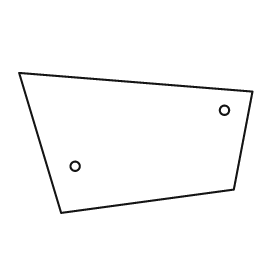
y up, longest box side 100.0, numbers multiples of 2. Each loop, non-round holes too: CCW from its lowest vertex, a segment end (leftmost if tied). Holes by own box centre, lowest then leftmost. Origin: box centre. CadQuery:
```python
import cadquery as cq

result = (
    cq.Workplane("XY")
    .moveTo(-32.0, -30.0)
    .lineTo(42.0, -20.0)
    .lineTo(50.0, 22.0)
    .lineTo(-50.0, 30.0)
    .close()
    .moveTo(-26.0, -10.0)
    .circle(2.0)
    .moveTo(38.0, 14.0)
    .circle(2.0)
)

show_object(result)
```